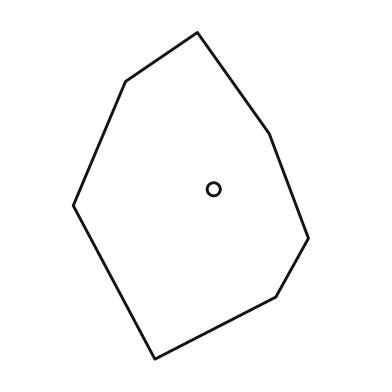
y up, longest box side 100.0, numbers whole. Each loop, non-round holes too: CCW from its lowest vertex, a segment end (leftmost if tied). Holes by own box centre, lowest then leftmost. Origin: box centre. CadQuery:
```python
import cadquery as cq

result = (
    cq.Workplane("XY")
    .moveTo(-11.0, -50.0)
    .lineTo(26.0, -31.0)
    .lineTo(36.0, -13.0)
    .lineTo(24.0, 19.0)
    .lineTo(2.0, 50.0)
    .lineTo(-20.0, 35.0)
    .lineTo(-36.0, -3.0)
    .close()
    .moveTo(7.0, 2.0)
    .circle(2.0)
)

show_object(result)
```